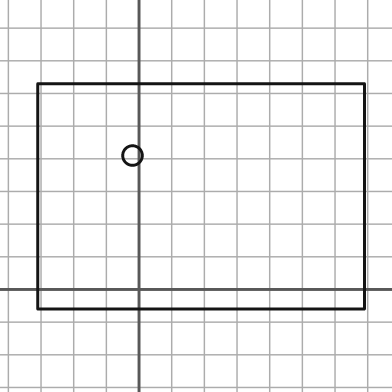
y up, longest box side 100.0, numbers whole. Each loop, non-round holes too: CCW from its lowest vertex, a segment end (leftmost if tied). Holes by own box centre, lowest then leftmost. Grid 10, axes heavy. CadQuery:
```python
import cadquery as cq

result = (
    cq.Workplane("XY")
    .moveTo(-31.0, -6.0)
    .lineTo(69.0, -6.0)
    .lineTo(69.0, 63.0)
    .lineTo(-31.0, 63.0)
    .close()
    .moveTo(-2.0, 41.0)
    .circle(3.0)
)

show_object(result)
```